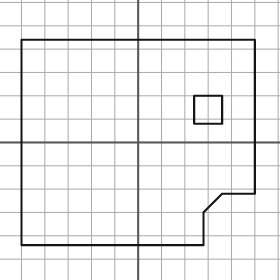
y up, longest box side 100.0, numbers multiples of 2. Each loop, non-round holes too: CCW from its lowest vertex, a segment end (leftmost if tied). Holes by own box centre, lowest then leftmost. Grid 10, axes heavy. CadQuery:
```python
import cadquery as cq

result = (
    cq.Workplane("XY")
    .moveTo(-50.0, -44.0)
    .lineTo(28.0, -44.0)
    .lineTo(28.0, -30.0)
    .lineTo(36.0, -22.0)
    .lineTo(50.0, -22.0)
    .lineTo(50.0, 44.0)
    .lineTo(-50.0, 44.0)
    .close()
    .moveTo(24.0, 8.0)
    .lineTo(36.0, 8.0)
    .lineTo(36.0, 20.0)
    .lineTo(24.0, 20.0)
    .close()
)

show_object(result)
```